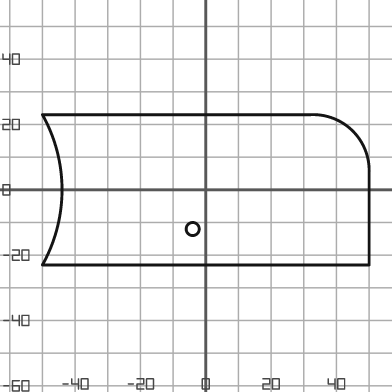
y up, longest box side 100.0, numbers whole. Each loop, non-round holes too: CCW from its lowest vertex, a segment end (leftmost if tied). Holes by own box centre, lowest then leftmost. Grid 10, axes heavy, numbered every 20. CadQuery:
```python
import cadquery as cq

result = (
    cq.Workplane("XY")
    .moveTo(-50.0, -23.0)
    .lineTo(50.0, -23.0)
    .lineTo(50.0, 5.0)
    .threePointArc((45.0, 18.0), (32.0, 23.0))
    .lineTo(-50.0, 23.0)
    .threePointArc((-44.0, 0.0), (-50.0, -23.0))
    .close()
    .moveTo(-4.0, -12.0)
    .circle(2.0)
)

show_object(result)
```